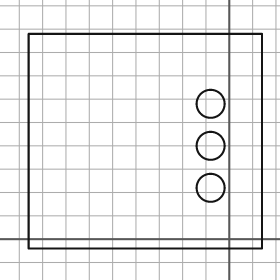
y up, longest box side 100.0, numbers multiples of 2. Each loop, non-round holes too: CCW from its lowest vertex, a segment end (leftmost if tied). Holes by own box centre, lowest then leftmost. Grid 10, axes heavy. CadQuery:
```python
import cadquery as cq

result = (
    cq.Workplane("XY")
    .moveTo(-86.0, -4.0)
    .lineTo(14.0, -4.0)
    .lineTo(14.0, 88.0)
    .lineTo(-86.0, 88.0)
    .close()
    .moveTo(-8.0, 22.0)
    .circle(6.0)
    .moveTo(-8.0, 40.0)
    .circle(6.0)
    .moveTo(-8.0, 58.0)
    .circle(6.0)
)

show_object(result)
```